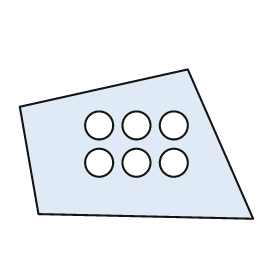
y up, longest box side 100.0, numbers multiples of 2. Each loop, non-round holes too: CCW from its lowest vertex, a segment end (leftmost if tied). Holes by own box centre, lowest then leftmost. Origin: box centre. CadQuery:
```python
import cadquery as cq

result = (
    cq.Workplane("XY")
    .moveTo(50.0, -32.0)
    .lineTo(22.0, 32.0)
    .lineTo(-50.0, 16.0)
    .lineTo(-42.0, -30.0)
    .close()
    .moveTo(-16.0, -8.0)
    .circle(6.0)
    .moveTo(0.0, -8.0)
    .circle(6.0)
    .moveTo(16.0, -8.0)
    .circle(6.0)
    .moveTo(-16.0, 8.0)
    .circle(6.0)
    .moveTo(0.0, 8.0)
    .circle(6.0)
    .moveTo(16.0, 8.0)
    .circle(6.0)
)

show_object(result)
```